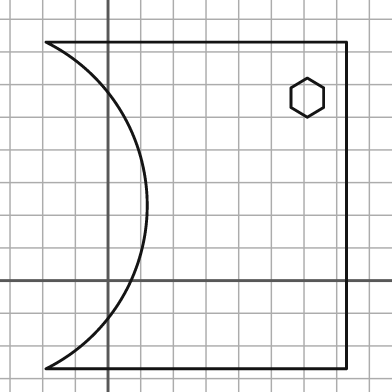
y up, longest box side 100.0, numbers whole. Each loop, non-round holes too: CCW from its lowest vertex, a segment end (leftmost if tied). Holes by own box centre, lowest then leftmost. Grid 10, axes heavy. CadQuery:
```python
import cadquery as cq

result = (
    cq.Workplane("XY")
    .moveTo(-19.0, -27.0)
    .lineTo(73.0, -27.0)
    .lineTo(73.0, 73.0)
    .lineTo(-19.0, 73.0)
    .threePointArc((12.0, 23.0), (-19.0, -27.0))
    .close()
    .moveTo(61.0, 50.0)
    .lineTo(66.0, 53.0)
    .lineTo(66.0, 59.0)
    .lineTo(61.0, 62.0)
    .lineTo(56.0, 59.0)
    .lineTo(56.0, 53.0)
    .close()
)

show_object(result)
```